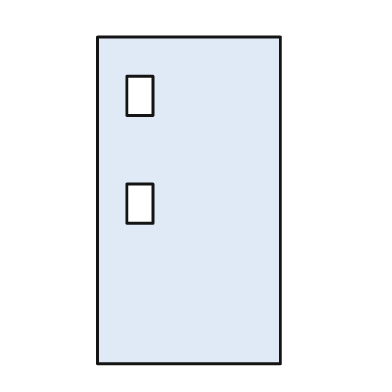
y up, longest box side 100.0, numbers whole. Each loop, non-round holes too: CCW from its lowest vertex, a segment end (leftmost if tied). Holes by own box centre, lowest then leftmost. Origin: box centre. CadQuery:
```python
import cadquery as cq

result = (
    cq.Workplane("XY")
    .moveTo(-28.0, -50.0)
    .lineTo(28.0, -50.0)
    .lineTo(28.0, 50.0)
    .lineTo(-28.0, 50.0)
    .close()
    .moveTo(-19.0, -7.0)
    .lineTo(-11.0, -7.0)
    .lineTo(-11.0, 5.0)
    .lineTo(-19.0, 5.0)
    .close()
    .moveTo(-19.0, 26.0)
    .lineTo(-11.0, 26.0)
    .lineTo(-11.0, 38.0)
    .lineTo(-19.0, 38.0)
    .close()
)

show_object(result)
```